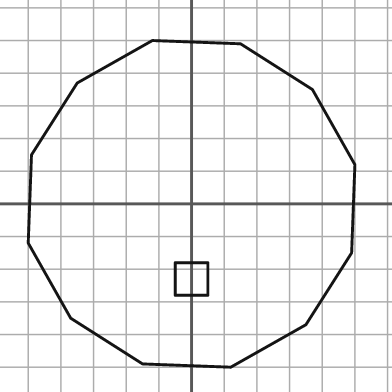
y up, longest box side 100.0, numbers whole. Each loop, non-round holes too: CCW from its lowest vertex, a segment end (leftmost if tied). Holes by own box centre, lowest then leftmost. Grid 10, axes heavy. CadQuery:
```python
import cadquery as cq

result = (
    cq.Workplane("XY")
    .moveTo(12.0, -50.0)
    .lineTo(35.0, -37.0)
    .lineTo(49.0, -15.0)
    .lineTo(50.0, 12.0)
    .lineTo(37.0, 35.0)
    .lineTo(15.0, 49.0)
    .lineTo(-12.0, 50.0)
    .lineTo(-35.0, 37.0)
    .lineTo(-49.0, 15.0)
    .lineTo(-50.0, -12.0)
    .lineTo(-37.0, -35.0)
    .lineTo(-15.0, -49.0)
    .close()
    .moveTo(-5.0, -28.0)
    .lineTo(5.0, -28.0)
    .lineTo(5.0, -18.0)
    .lineTo(-5.0, -18.0)
    .close()
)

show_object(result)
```